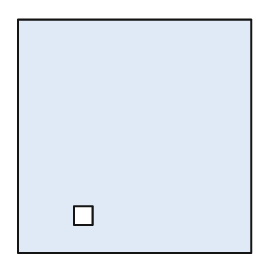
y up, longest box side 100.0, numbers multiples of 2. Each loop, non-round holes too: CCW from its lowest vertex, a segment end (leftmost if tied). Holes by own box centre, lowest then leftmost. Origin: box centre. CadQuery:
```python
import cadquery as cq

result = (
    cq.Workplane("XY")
    .moveTo(-50.0, -50.0)
    .lineTo(50.0, -50.0)
    .lineTo(50.0, 50.0)
    .lineTo(-50.0, 50.0)
    .close()
    .moveTo(-26.0, -38.0)
    .lineTo(-18.0, -38.0)
    .lineTo(-18.0, -30.0)
    .lineTo(-26.0, -30.0)
    .close()
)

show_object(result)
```